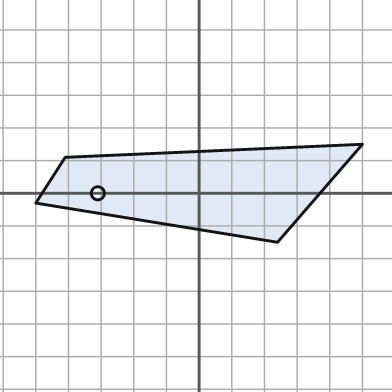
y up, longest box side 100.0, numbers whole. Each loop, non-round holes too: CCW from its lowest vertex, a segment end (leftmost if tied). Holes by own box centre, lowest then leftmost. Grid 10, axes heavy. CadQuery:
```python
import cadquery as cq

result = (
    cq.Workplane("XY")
    .moveTo(24.0, -15.0)
    .lineTo(50.0, 15.0)
    .lineTo(-41.0, 11.0)
    .lineTo(-50.0, -3.0)
    .close()
    .moveTo(-31.0, 0.0)
    .circle(2.0)
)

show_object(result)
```